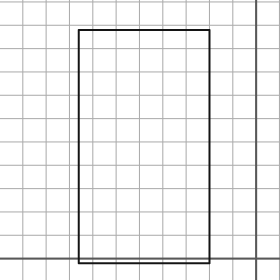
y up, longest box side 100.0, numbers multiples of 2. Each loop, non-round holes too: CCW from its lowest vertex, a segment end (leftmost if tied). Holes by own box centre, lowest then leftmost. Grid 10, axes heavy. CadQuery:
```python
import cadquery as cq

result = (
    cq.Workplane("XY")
    .moveTo(-76.0, -2.0)
    .lineTo(-20.0, -2.0)
    .lineTo(-20.0, 98.0)
    .lineTo(-76.0, 98.0)
    .close()
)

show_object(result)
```